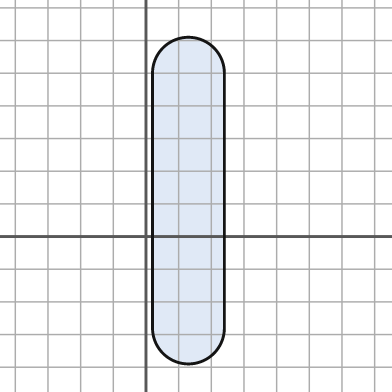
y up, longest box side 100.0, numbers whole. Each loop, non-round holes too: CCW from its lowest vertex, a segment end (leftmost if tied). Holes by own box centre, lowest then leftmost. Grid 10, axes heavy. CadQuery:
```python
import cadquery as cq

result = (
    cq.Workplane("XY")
    .moveTo(2.0, -28.0)
    .threePointArc((13.0, -39.0), (24.0, -28.0))
    .lineTo(24.0, 50.0)
    .threePointArc((13.0, 61.0), (2.0, 50.0))
    .close()
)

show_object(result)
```